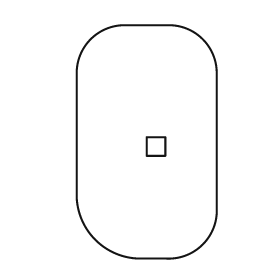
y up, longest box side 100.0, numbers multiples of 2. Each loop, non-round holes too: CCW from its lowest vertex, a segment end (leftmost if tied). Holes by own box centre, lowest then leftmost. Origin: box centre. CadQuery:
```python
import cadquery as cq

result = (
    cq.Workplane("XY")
    .moveTo(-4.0, -50.0)
    .lineTo(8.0, -50.0)
    .threePointArc((24.0, -44.0), (30.0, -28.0))
    .lineTo(30.0, 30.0)
    .threePointArc((24.0, 44.0), (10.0, 50.0))
    .lineTo(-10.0, 50.0)
    .threePointArc((-24.0, 44.0), (-30.0, 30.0))
    .lineTo(-30.0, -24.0)
    .threePointArc((-22.0, -42.0), (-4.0, -50.0))
    .close()
    .moveTo(0.0, -6.0)
    .lineTo(8.0, -6.0)
    .lineTo(8.0, 2.0)
    .lineTo(0.0, 2.0)
    .close()
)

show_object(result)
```